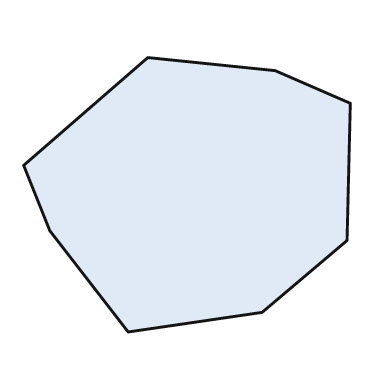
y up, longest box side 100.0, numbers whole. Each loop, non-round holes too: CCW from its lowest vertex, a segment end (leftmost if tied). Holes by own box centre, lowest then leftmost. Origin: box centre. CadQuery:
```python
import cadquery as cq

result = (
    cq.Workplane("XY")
    .moveTo(-18.0, -42.0)
    .lineTo(23.0, -36.0)
    .lineTo(49.0, -14.0)
    .lineTo(50.0, 28.0)
    .lineTo(27.0, 38.0)
    .lineTo(-12.0, 42.0)
    .lineTo(-50.0, 9.0)
    .lineTo(-42.0, -11.0)
    .close()
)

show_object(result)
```